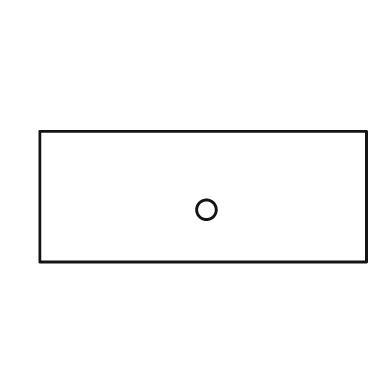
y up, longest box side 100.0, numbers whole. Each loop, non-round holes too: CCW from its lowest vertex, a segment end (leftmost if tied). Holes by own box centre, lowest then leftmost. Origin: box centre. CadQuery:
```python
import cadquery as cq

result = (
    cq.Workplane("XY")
    .moveTo(-50.0, -20.0)
    .lineTo(50.0, -20.0)
    .lineTo(50.0, 20.0)
    .lineTo(-50.0, 20.0)
    .close()
    .moveTo(1.0, -4.0)
    .circle(3.0)
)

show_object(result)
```